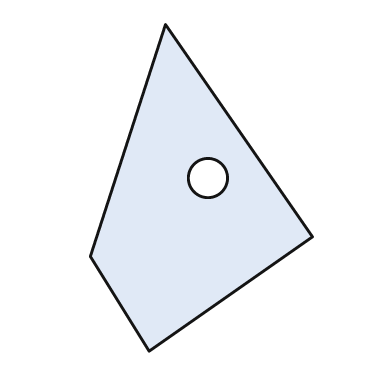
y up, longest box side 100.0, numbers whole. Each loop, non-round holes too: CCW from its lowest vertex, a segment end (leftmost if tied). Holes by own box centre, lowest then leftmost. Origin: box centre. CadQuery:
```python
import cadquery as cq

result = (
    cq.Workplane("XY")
    .moveTo(-16.0, -50.0)
    .lineTo(34.0, -15.0)
    .lineTo(-11.0, 50.0)
    .lineTo(-34.0, -21.0)
    .close()
    .moveTo(2.0, 3.0)
    .circle(6.0)
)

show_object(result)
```